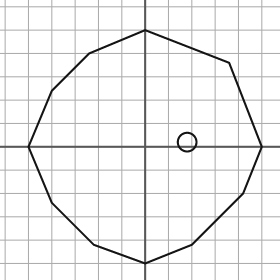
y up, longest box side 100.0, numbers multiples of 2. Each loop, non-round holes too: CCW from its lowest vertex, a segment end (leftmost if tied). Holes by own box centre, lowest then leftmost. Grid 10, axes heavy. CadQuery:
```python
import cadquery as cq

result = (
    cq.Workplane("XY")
    .moveTo(0.0, -50.0)
    .lineTo(20.0, -42.0)
    .lineTo(42.0, -20.0)
    .lineTo(50.0, 0.0)
    .lineTo(36.0, 36.0)
    .lineTo(0.0, 50.0)
    .lineTo(-24.0, 40.0)
    .lineTo(-40.0, 24.0)
    .lineTo(-50.0, 0.0)
    .lineTo(-40.0, -24.0)
    .lineTo(-22.0, -42.0)
    .close()
    .moveTo(18.0, 2.0)
    .circle(4.0)
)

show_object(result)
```